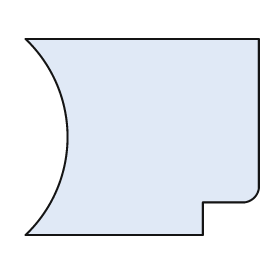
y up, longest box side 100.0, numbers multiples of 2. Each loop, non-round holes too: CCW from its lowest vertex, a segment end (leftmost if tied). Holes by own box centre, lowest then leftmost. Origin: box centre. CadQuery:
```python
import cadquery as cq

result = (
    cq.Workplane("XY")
    .moveTo(-50.0, -42.0)
    .lineTo(26.0, -42.0)
    .lineTo(26.0, -28.0)
    .lineTo(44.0, -28.0)
    .threePointArc((48.0, -26.0), (50.0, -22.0))
    .lineTo(50.0, 42.0)
    .lineTo(-50.0, 42.0)
    .threePointArc((-32.0, 0.0), (-50.0, -42.0))
    .close()
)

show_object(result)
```